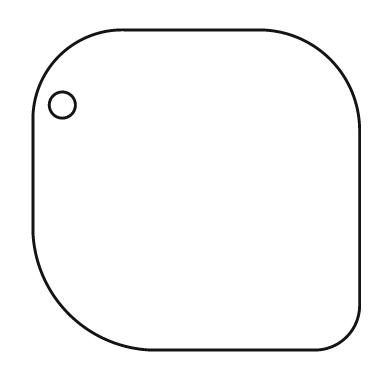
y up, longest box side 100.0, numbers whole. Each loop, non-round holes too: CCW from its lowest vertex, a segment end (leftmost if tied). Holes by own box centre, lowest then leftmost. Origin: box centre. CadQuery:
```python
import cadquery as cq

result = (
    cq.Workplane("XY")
    .moveTo(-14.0, -49.0)
    .lineTo(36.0, -49.0)
    .threePointArc((46.0, -45.0), (50.0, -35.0))
    .lineTo(50.0, 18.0)
    .threePointArc((41.0, 40.0), (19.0, 49.0))
    .lineTo(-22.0, 49.0)
    .threePointArc((-42.0, 41.0), (-50.0, 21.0))
    .lineTo(-50.0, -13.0)
    .threePointArc((-39.0, -38.0), (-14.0, -49.0))
    .close()
    .moveTo(-41.0, 26.0)
    .circle(4.0)
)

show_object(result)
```